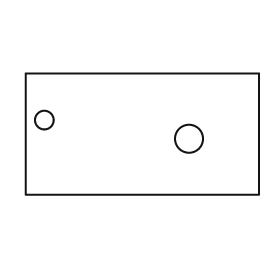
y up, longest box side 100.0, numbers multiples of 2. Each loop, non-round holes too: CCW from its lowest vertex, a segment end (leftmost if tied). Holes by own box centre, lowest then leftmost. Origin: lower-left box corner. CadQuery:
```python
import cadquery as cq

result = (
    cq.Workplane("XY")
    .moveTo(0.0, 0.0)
    .lineTo(100.0, 0.0)
    .lineTo(100.0, 52.0)
    .lineTo(0.0, 52.0)
    .close()
    .moveTo(70.0, 24.0)
    .circle(6.0)
    .moveTo(8.0, 32.0)
    .circle(4.0)
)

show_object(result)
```